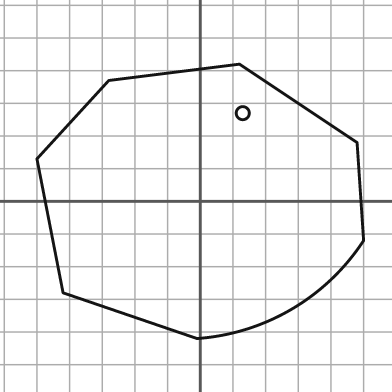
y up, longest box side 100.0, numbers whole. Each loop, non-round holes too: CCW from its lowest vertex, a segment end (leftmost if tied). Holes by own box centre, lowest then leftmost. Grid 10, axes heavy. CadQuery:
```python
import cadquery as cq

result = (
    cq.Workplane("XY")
    .moveTo(-1.0, -42.0)
    .threePointArc((28.0, -33.0), (50.0, -12.0))
    .lineTo(48.0, 18.0)
    .lineTo(12.0, 42.0)
    .lineTo(-28.0, 37.0)
    .lineTo(-50.0, 13.0)
    .lineTo(-42.0, -28.0)
    .close()
    .moveTo(13.0, 27.0)
    .circle(2.0)
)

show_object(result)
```